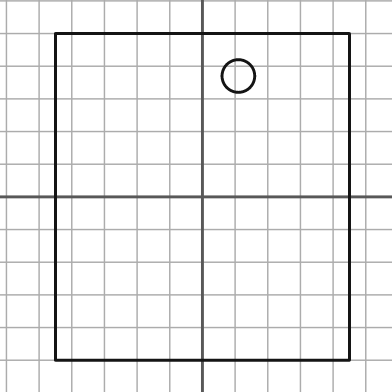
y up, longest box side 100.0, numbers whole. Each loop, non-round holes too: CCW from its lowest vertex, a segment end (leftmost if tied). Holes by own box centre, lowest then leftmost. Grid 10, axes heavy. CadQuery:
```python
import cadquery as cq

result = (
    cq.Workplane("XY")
    .moveTo(-45.0, -50.0)
    .lineTo(45.0, -50.0)
    .lineTo(45.0, 50.0)
    .lineTo(-45.0, 50.0)
    .close()
    .moveTo(11.0, 37.0)
    .circle(5.0)
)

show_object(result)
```